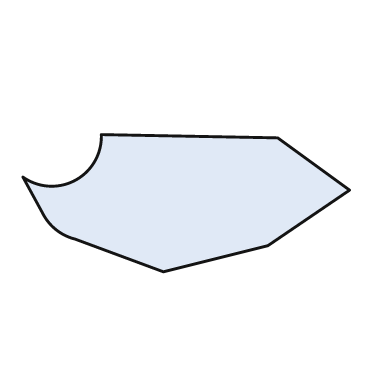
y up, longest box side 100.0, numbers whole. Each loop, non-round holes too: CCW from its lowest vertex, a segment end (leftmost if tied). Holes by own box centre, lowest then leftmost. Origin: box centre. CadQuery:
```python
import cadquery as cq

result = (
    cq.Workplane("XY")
    .moveTo(-7.0, -21.0)
    .lineTo(25.0, -13.0)
    .lineTo(50.0, 4.0)
    .lineTo(28.0, 20.0)
    .lineTo(-26.0, 21.0)
    .threePointArc((-34.0, 7.0), (-50.0, 8.0))
    .lineTo(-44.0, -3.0)
    .threePointArc((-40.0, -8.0), (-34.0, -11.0))
    .close()
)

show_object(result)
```